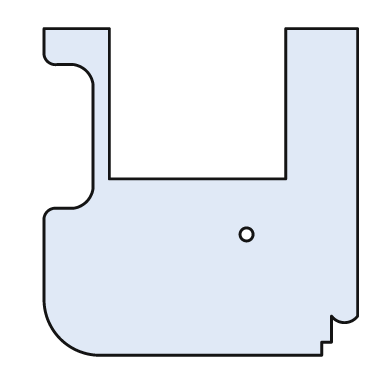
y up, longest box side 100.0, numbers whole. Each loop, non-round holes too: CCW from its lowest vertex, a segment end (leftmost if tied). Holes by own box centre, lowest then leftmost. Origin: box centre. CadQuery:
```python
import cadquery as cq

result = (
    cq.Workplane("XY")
    .moveTo(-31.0, -50.0)
    .lineTo(37.0, -50.0)
    .lineTo(37.0, -46.0)
    .lineTo(40.0, -46.0)
    .lineTo(40.0, -38.0)
    .threePointArc((44.0, -40.0), (48.0, -38.0))
    .lineTo(48.0, 50.0)
    .lineTo(26.0, 50.0)
    .lineTo(26.0, 4.0)
    .lineTo(-28.0, 4.0)
    .lineTo(-28.0, 50.0)
    .lineTo(-48.0, 50.0)
    .lineTo(-48.0, 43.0)
    .threePointArc((-47.0, 40.0), (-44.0, 39.0))
    .lineTo(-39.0, 39.0)
    .threePointArc((-35.0, 37.0), (-33.0, 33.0))
    .lineTo(-33.0, 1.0)
    .threePointArc((-35.0, -3.0), (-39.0, -5.0))
    .lineTo(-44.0, -5.0)
    .threePointArc((-47.0, -6.0), (-48.0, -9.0))
    .lineTo(-48.0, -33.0)
    .threePointArc((-43.0, -45.0), (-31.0, -50.0))
    .close()
    .moveTo(14.0, -13.0)
    .circle(2.0)
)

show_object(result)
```